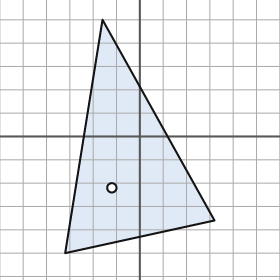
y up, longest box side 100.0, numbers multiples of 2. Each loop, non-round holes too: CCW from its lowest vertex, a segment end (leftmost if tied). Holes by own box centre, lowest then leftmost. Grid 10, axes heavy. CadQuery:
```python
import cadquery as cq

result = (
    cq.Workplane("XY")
    .moveTo(-32.0, -50.0)
    .lineTo(32.0, -36.0)
    .lineTo(-16.0, 50.0)
    .close()
    .moveTo(-12.0, -22.0)
    .circle(2.0)
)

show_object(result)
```